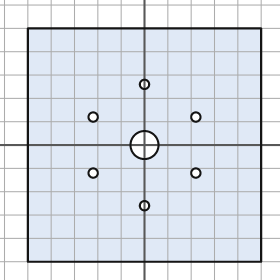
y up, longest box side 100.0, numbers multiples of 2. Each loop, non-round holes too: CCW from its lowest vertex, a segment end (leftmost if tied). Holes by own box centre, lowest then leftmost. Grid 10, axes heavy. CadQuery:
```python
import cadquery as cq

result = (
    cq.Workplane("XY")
    .moveTo(-50.0, -50.0)
    .lineTo(50.0, -50.0)
    .lineTo(50.0, 50.0)
    .lineTo(-50.0, 50.0)
    .close()
    .moveTo(0.0, -26.0)
    .circle(2.0)
    .moveTo(-22.0, -12.0)
    .circle(2.0)
    .moveTo(22.0, -12.0)
    .circle(2.0)
    .moveTo(0.0, 0.0)
    .circle(6.0)
    .moveTo(-22.0, 12.0)
    .circle(2.0)
    .moveTo(22.0, 12.0)
    .circle(2.0)
    .moveTo(0.0, 26.0)
    .circle(2.0)
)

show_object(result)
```